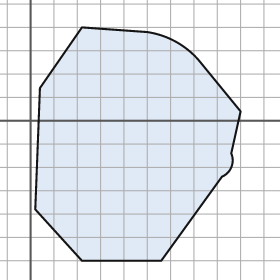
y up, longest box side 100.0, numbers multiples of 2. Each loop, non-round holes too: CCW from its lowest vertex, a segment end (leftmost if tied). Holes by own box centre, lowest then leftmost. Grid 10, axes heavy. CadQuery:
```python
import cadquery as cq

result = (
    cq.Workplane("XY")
    .moveTo(22.0, -60.0)
    .lineTo(56.0, -60.0)
    .lineTo(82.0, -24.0)
    .threePointArc((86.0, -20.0), (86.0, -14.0))
    .lineTo(90.0, 4.0)
    .lineTo(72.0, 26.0)
    .threePointArc((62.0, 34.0), (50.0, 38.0))
    .lineTo(22.0, 40.0)
    .lineTo(4.0, 14.0)
    .lineTo(2.0, -38.0)
    .close()
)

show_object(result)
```